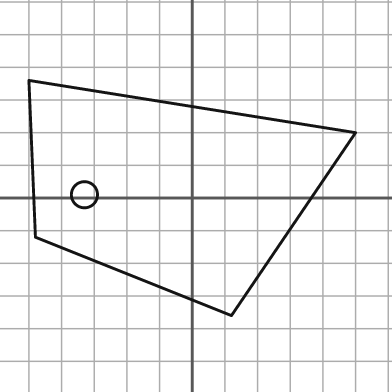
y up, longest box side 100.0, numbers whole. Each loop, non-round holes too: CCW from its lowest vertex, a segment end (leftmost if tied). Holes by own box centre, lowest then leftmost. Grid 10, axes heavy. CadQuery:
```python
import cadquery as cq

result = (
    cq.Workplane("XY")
    .moveTo(12.0, -36.0)
    .lineTo(50.0, 20.0)
    .lineTo(-50.0, 36.0)
    .lineTo(-48.0, -12.0)
    .close()
    .moveTo(-33.0, 1.0)
    .circle(4.0)
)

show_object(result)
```